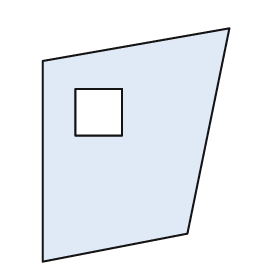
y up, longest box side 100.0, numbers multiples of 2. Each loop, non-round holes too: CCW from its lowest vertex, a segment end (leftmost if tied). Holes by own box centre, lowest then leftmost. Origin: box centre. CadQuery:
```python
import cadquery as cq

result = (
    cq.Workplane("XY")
    .moveTo(-40.0, -50.0)
    .lineTo(22.0, -38.0)
    .lineTo(40.0, 50.0)
    .lineTo(-40.0, 36.0)
    .close()
    .moveTo(-26.0, 4.0)
    .lineTo(-6.0, 4.0)
    .lineTo(-6.0, 24.0)
    .lineTo(-26.0, 24.0)
    .close()
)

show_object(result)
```